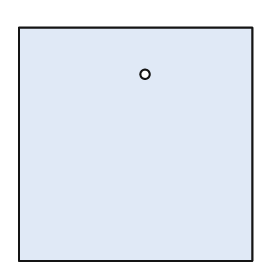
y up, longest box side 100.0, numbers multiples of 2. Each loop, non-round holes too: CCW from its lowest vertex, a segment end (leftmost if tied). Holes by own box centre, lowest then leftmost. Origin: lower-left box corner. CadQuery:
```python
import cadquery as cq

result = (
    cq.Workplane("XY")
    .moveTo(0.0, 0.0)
    .lineTo(100.0, 0.0)
    .lineTo(100.0, 100.0)
    .lineTo(0.0, 100.0)
    .close()
    .moveTo(54.0, 80.0)
    .circle(2.0)
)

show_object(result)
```